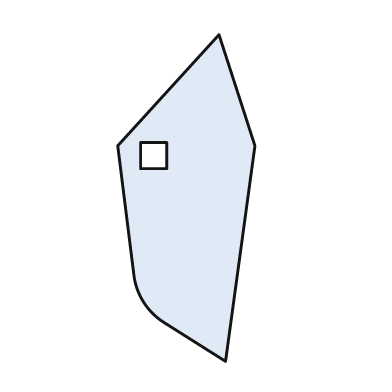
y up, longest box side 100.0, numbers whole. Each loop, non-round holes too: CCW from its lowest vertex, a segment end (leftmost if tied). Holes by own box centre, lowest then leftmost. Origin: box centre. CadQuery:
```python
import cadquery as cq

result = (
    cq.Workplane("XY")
    .moveTo(12.0, -50.0)
    .lineTo(21.0, 16.0)
    .lineTo(10.0, 50.0)
    .lineTo(-21.0, 16.0)
    .lineTo(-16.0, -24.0)
    .threePointArc((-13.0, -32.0), (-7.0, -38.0))
    .close()
    .moveTo(-14.0, 9.0)
    .lineTo(-6.0, 9.0)
    .lineTo(-6.0, 17.0)
    .lineTo(-14.0, 17.0)
    .close()
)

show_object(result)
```